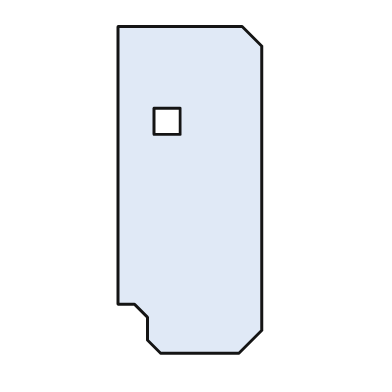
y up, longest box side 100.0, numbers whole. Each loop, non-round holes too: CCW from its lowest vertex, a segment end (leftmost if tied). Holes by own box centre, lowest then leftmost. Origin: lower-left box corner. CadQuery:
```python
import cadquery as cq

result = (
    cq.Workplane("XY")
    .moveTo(13.0, 0.0)
    .lineTo(37.0, 0.0)
    .lineTo(44.0, 7.0)
    .lineTo(44.0, 94.0)
    .lineTo(38.0, 100.0)
    .lineTo(0.0, 100.0)
    .lineTo(0.0, 15.0)
    .lineTo(5.0, 15.0)
    .lineTo(9.0, 11.0)
    .lineTo(9.0, 4.0)
    .close()
    .moveTo(11.0, 67.0)
    .lineTo(19.0, 67.0)
    .lineTo(19.0, 75.0)
    .lineTo(11.0, 75.0)
    .close()
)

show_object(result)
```